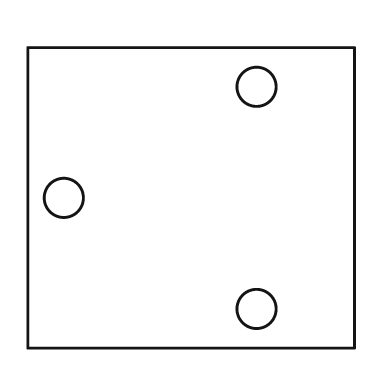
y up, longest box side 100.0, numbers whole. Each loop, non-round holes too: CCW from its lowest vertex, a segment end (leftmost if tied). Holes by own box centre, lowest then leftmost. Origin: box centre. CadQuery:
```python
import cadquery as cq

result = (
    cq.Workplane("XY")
    .moveTo(-50.0, -46.0)
    .lineTo(50.0, -46.0)
    .lineTo(50.0, 46.0)
    .lineTo(-50.0, 46.0)
    .close()
    .moveTo(20.0, -34.0)
    .circle(6.0)
    .moveTo(-39.0, 0.0)
    .circle(6.0)
    .moveTo(20.0, 34.0)
    .circle(6.0)
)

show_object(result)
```